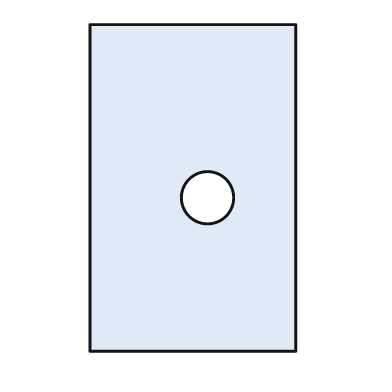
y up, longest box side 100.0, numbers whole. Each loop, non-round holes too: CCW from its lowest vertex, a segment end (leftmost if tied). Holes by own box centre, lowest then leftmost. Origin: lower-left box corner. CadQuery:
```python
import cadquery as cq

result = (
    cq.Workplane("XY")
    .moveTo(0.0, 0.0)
    .lineTo(63.0, 0.0)
    .lineTo(63.0, 100.0)
    .lineTo(0.0, 100.0)
    .close()
    .moveTo(36.0, 47.0)
    .circle(8.0)
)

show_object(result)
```